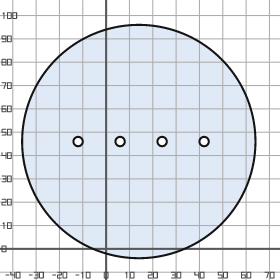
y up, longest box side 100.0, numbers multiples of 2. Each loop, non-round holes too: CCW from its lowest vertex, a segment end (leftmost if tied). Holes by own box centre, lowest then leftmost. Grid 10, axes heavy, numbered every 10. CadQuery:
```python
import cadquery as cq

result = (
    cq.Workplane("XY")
    .moveTo(14.0, 46.0)
    .circle(50.0)
    .moveTo(-12.0, 46.0)
    .circle(2.0)
    .moveTo(6.0, 46.0)
    .circle(2.0)
    .moveTo(24.0, 46.0)
    .circle(2.0)
    .moveTo(42.0, 46.0)
    .circle(2.0)
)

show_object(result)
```